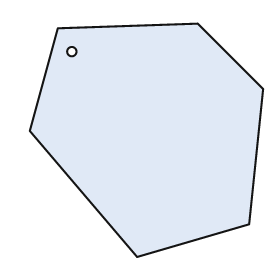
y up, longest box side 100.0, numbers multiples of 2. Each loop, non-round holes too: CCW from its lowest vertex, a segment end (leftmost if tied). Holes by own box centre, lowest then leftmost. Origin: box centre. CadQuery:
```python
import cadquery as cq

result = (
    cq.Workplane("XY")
    .moveTo(-4.0, -50.0)
    .lineTo(44.0, -36.0)
    .lineTo(50.0, 22.0)
    .lineTo(22.0, 50.0)
    .lineTo(-38.0, 48.0)
    .lineTo(-50.0, 4.0)
    .close()
    .moveTo(-32.0, 38.0)
    .circle(2.0)
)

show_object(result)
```